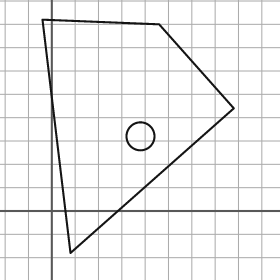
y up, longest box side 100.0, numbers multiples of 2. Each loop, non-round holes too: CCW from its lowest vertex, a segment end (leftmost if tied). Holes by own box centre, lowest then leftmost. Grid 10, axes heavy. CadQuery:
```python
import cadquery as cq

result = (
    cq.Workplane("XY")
    .moveTo(8.0, -18.0)
    .lineTo(78.0, 44.0)
    .lineTo(46.0, 80.0)
    .lineTo(-4.0, 82.0)
    .close()
    .moveTo(38.0, 32.0)
    .circle(6.0)
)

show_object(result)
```